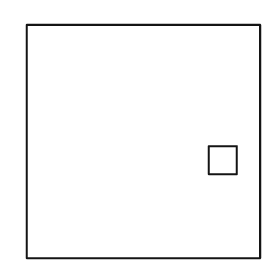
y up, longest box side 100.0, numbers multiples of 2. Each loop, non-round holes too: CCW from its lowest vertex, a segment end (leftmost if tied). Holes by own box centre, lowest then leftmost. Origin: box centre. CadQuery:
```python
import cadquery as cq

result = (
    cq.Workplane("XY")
    .moveTo(-50.0, -50.0)
    .lineTo(50.0, -50.0)
    .lineTo(50.0, 50.0)
    .lineTo(-50.0, 50.0)
    .close()
    .moveTo(28.0, -14.0)
    .lineTo(40.0, -14.0)
    .lineTo(40.0, -2.0)
    .lineTo(28.0, -2.0)
    .close()
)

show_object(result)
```